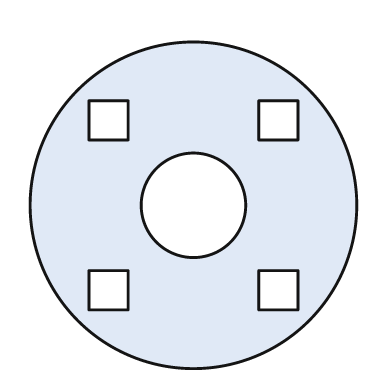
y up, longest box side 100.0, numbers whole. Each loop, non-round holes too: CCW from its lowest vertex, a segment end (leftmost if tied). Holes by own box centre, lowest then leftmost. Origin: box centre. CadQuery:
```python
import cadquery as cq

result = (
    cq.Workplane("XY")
    .moveTo(0.0, 0.0)
    .circle(50.0)
    .moveTo(-32.0, -32.0)
    .lineTo(-20.0, -32.0)
    .lineTo(-20.0, -20.0)
    .lineTo(-32.0, -20.0)
    .close()
    .moveTo(20.0, -32.0)
    .lineTo(32.0, -32.0)
    .lineTo(32.0, -20.0)
    .lineTo(20.0, -20.0)
    .close()
    .moveTo(0.0, 0.0)
    .circle(16.0)
    .moveTo(-32.0, 20.0)
    .lineTo(-20.0, 20.0)
    .lineTo(-20.0, 32.0)
    .lineTo(-32.0, 32.0)
    .close()
    .moveTo(20.0, 20.0)
    .lineTo(32.0, 20.0)
    .lineTo(32.0, 32.0)
    .lineTo(20.0, 32.0)
    .close()
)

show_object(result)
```